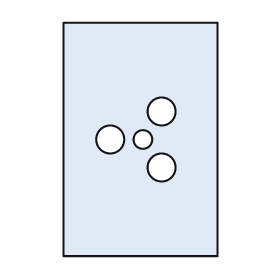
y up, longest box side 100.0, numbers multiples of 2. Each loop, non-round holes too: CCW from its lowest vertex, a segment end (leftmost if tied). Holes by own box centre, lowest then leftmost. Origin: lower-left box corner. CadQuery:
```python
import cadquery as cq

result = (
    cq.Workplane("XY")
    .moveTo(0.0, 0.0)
    .lineTo(66.0, 0.0)
    .lineTo(66.0, 100.0)
    .lineTo(0.0, 100.0)
    .close()
    .moveTo(42.0, 38.0)
    .circle(6.0)
    .moveTo(20.0, 50.0)
    .circle(6.0)
    .moveTo(34.0, 50.0)
    .circle(4.0)
    .moveTo(42.0, 62.0)
    .circle(6.0)
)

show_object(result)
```